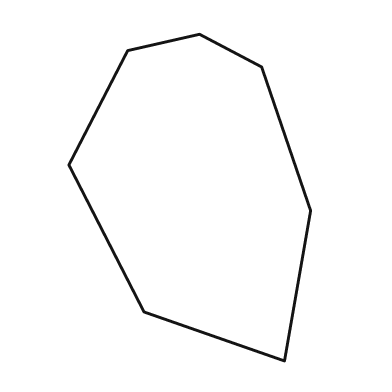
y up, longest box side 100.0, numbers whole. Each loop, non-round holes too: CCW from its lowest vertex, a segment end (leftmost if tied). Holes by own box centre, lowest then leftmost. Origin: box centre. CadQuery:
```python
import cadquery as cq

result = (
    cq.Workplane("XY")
    .moveTo(29.0, -50.0)
    .lineTo(37.0, -4.0)
    .lineTo(22.0, 40.0)
    .lineTo(3.0, 50.0)
    .lineTo(-19.0, 45.0)
    .lineTo(-37.0, 10.0)
    .lineTo(-14.0, -35.0)
    .close()
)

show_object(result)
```